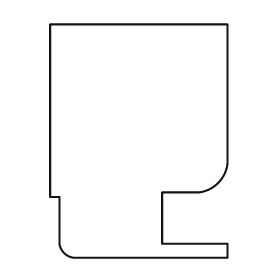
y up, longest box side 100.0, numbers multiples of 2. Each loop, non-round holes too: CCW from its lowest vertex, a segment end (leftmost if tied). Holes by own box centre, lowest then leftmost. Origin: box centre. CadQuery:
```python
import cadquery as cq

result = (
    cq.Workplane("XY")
    .moveTo(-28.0, -50.0)
    .lineTo(38.0, -50.0)
    .lineTo(38.0, -44.0)
    .lineTo(10.0, -44.0)
    .lineTo(10.0, -22.0)
    .lineTo(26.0, -22.0)
    .threePointArc((34.0, -18.0), (38.0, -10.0))
    .lineTo(38.0, 50.0)
    .lineTo(-38.0, 50.0)
    .lineTo(-38.0, -24.0)
    .lineTo(-34.0, -24.0)
    .lineTo(-34.0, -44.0)
    .threePointArc((-32.0, -48.0), (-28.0, -50.0))
    .close()
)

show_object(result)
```